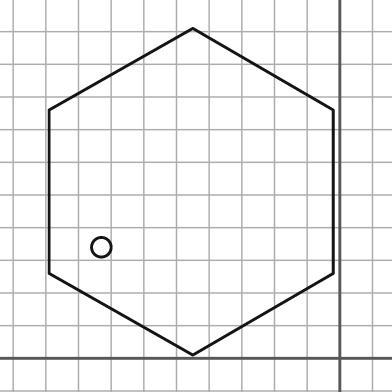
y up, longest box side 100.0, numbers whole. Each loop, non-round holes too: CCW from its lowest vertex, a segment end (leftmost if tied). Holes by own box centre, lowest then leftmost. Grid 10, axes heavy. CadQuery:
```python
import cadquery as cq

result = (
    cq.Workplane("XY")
    .moveTo(-45.0, 1.0)
    .lineTo(-2.0, 26.0)
    .lineTo(-2.0, 76.0)
    .lineTo(-45.0, 101.0)
    .lineTo(-89.0, 76.0)
    .lineTo(-89.0, 26.0)
    .close()
    .moveTo(-73.0, 34.0)
    .circle(3.0)
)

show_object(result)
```